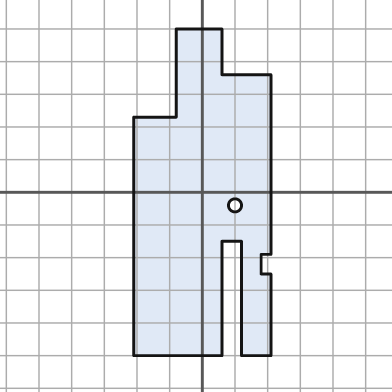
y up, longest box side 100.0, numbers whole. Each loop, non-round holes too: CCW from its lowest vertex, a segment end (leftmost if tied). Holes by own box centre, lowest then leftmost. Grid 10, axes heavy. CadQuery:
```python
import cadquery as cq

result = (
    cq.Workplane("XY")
    .moveTo(-21.0, -50.0)
    .lineTo(6.0, -50.0)
    .lineTo(6.0, -15.0)
    .lineTo(12.0, -15.0)
    .lineTo(12.0, -50.0)
    .lineTo(21.0, -50.0)
    .lineTo(21.0, -25.0)
    .lineTo(18.0, -25.0)
    .lineTo(18.0, -19.0)
    .lineTo(21.0, -19.0)
    .lineTo(21.0, 36.0)
    .lineTo(6.0, 36.0)
    .lineTo(6.0, 50.0)
    .lineTo(-8.0, 50.0)
    .lineTo(-8.0, 23.0)
    .lineTo(-21.0, 23.0)
    .close()
    .moveTo(10.0, -4.0)
    .circle(2.0)
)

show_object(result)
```